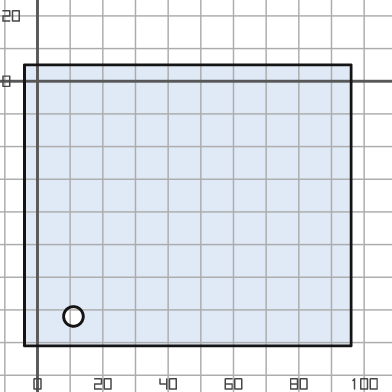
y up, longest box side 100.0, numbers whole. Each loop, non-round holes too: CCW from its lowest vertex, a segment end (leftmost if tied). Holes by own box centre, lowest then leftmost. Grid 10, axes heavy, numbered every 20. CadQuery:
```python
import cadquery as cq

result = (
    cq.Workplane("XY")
    .moveTo(-4.0, -81.0)
    .lineTo(96.0, -81.0)
    .lineTo(96.0, 5.0)
    .lineTo(-4.0, 5.0)
    .close()
    .moveTo(11.0, -72.0)
    .circle(3.0)
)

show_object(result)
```